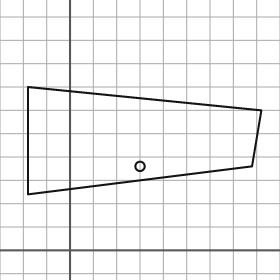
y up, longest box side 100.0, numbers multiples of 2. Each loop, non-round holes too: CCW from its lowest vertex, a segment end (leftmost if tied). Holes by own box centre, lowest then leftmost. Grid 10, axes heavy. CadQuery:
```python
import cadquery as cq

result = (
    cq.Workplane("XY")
    .moveTo(-18.0, 24.0)
    .lineTo(78.0, 36.0)
    .lineTo(82.0, 60.0)
    .lineTo(-18.0, 70.0)
    .close()
    .moveTo(30.0, 36.0)
    .circle(2.0)
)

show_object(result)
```